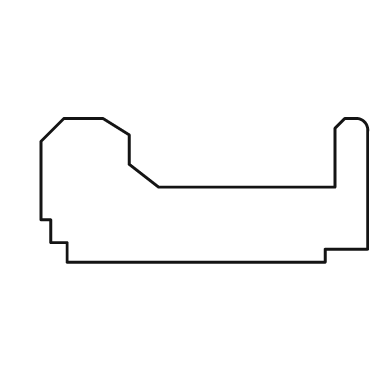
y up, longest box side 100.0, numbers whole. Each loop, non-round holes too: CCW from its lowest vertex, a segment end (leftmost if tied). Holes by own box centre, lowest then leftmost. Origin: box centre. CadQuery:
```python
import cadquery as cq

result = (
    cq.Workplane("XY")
    .moveTo(-42.0, -22.0)
    .lineTo(37.0, -22.0)
    .lineTo(37.0, -18.0)
    .lineTo(50.0, -18.0)
    .lineTo(50.0, 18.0)
    .threePointArc((49.0, 21.0), (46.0, 22.0))
    .lineTo(43.0, 22.0)
    .lineTo(40.0, 19.0)
    .lineTo(40.0, 1.0)
    .lineTo(-14.0, 1.0)
    .lineTo(-23.0, 8.0)
    .lineTo(-23.0, 17.0)
    .lineTo(-31.0, 22.0)
    .lineTo(-43.0, 22.0)
    .lineTo(-50.0, 15.0)
    .lineTo(-50.0, -9.0)
    .lineTo(-47.0, -9.0)
    .lineTo(-47.0, -16.0)
    .lineTo(-42.0, -16.0)
    .close()
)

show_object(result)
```